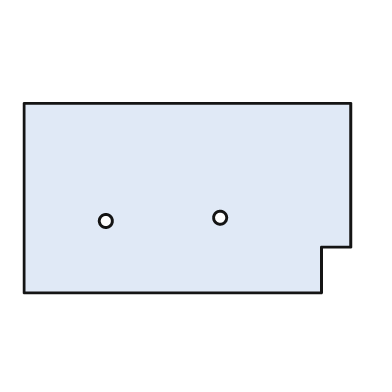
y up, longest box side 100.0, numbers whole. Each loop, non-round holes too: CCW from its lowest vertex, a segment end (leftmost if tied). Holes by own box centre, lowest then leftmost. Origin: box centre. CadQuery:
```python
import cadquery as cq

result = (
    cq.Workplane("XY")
    .moveTo(-50.0, -29.0)
    .lineTo(41.0, -29.0)
    .lineTo(41.0, -15.0)
    .lineTo(50.0, -15.0)
    .lineTo(50.0, 29.0)
    .lineTo(-50.0, 29.0)
    .close()
    .moveTo(-25.0, -7.0)
    .circle(2.0)
    .moveTo(10.0, -6.0)
    .circle(2.0)
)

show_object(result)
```